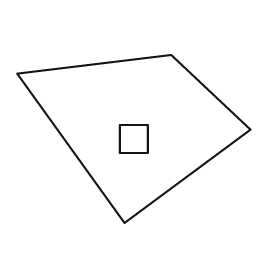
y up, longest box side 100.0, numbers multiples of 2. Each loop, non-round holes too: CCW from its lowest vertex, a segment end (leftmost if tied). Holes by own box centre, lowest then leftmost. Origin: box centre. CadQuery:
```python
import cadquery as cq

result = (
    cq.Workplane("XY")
    .moveTo(-4.0, -36.0)
    .lineTo(50.0, 4.0)
    .lineTo(16.0, 36.0)
    .lineTo(-50.0, 28.0)
    .close()
    .moveTo(-6.0, -6.0)
    .lineTo(6.0, -6.0)
    .lineTo(6.0, 6.0)
    .lineTo(-6.0, 6.0)
    .close()
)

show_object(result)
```